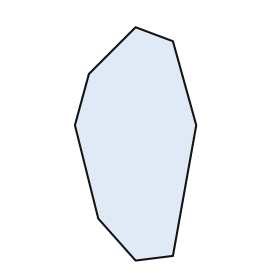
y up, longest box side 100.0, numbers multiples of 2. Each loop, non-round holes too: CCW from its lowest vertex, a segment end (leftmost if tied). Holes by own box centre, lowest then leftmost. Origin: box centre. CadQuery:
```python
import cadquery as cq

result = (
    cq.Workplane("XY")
    .moveTo(0.0, -50.0)
    .lineTo(16.0, -48.0)
    .lineTo(26.0, 8.0)
    .lineTo(16.0, 44.0)
    .lineTo(0.0, 50.0)
    .lineTo(-20.0, 30.0)
    .lineTo(-26.0, 8.0)
    .lineTo(-16.0, -32.0)
    .close()
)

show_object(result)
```